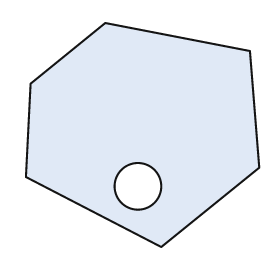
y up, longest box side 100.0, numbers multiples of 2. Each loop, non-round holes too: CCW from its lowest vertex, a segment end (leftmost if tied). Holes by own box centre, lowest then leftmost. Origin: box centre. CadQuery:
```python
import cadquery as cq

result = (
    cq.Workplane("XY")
    .moveTo(8.0, -48.0)
    .lineTo(50.0, -14.0)
    .lineTo(46.0, 36.0)
    .lineTo(-16.0, 48.0)
    .lineTo(-48.0, 22.0)
    .lineTo(-50.0, -18.0)
    .close()
    .moveTo(-2.0, -22.0)
    .circle(10.0)
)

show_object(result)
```